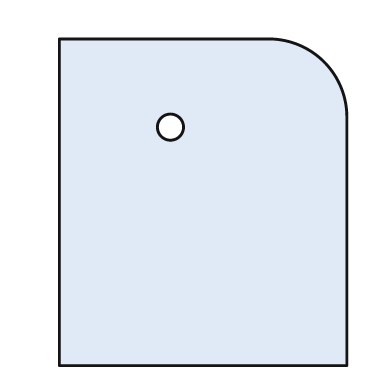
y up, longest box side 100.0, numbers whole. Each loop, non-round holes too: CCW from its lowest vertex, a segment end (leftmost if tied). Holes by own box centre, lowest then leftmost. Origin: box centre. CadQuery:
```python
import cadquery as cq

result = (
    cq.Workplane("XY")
    .moveTo(-44.0, -50.0)
    .lineTo(44.0, -50.0)
    .lineTo(44.0, 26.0)
    .threePointArc((37.0, 43.0), (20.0, 50.0))
    .lineTo(-44.0, 50.0)
    .close()
    .moveTo(-10.0, 23.0)
    .circle(4.0)
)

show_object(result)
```